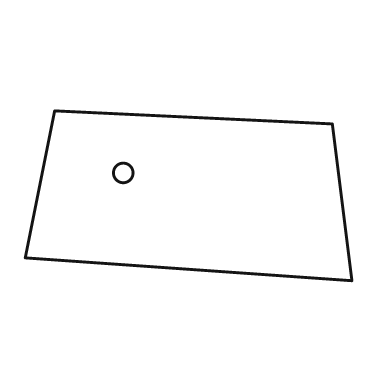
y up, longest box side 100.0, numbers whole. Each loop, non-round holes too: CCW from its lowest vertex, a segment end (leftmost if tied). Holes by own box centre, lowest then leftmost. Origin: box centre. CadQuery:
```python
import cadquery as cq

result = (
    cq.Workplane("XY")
    .moveTo(50.0, -26.0)
    .lineTo(44.0, 22.0)
    .lineTo(-41.0, 26.0)
    .lineTo(-50.0, -19.0)
    .close()
    .moveTo(-20.0, 7.0)
    .circle(3.0)
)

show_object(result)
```